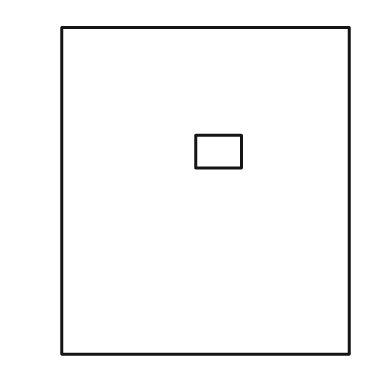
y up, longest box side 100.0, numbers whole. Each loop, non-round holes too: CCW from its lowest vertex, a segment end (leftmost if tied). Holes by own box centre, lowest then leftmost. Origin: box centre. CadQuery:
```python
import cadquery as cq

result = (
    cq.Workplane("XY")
    .moveTo(-44.0, -50.0)
    .lineTo(44.0, -50.0)
    .lineTo(44.0, 50.0)
    .lineTo(-44.0, 50.0)
    .close()
    .moveTo(-3.0, 7.0)
    .lineTo(11.0, 7.0)
    .lineTo(11.0, 17.0)
    .lineTo(-3.0, 17.0)
    .close()
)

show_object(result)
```